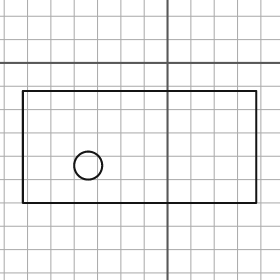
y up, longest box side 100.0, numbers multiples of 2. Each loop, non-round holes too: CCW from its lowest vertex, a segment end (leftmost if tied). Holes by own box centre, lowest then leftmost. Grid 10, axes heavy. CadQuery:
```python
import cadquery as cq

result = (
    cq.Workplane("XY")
    .moveTo(-62.0, -60.0)
    .lineTo(38.0, -60.0)
    .lineTo(38.0, -12.0)
    .lineTo(-62.0, -12.0)
    .close()
    .moveTo(-34.0, -44.0)
    .circle(6.0)
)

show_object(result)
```